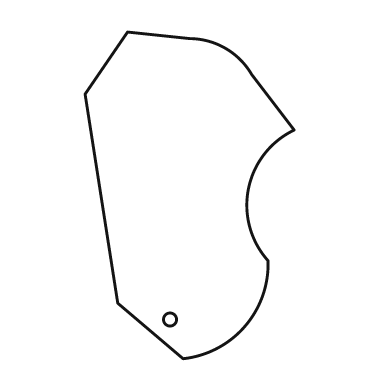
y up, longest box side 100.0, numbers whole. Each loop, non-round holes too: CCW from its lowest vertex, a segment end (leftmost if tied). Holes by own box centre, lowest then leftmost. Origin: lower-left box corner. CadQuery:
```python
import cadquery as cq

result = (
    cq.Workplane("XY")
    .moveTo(30.0, 0.0)
    .threePointArc((49.0, 10.0), (56.0, 30.0))
    .threePointArc((50.0, 52.0), (64.0, 70.0))
    .lineTo(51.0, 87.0)
    .threePointArc((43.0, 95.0), (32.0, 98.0))
    .lineTo(13.0, 100.0)
    .lineTo(0.0, 81.0)
    .lineTo(10.0, 17.0)
    .close()
    .moveTo(26.0, 12.0)
    .circle(2.0)
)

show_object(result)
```